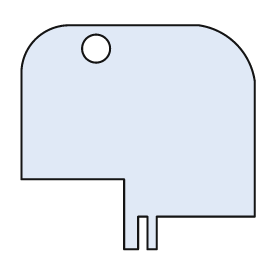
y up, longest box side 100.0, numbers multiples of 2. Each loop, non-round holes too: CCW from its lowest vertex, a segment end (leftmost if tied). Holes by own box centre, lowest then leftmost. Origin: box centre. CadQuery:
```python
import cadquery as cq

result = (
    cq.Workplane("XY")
    .moveTo(-6.0, -48.0)
    .lineTo(0.0, -48.0)
    .lineTo(0.0, -34.0)
    .lineTo(4.0, -34.0)
    .lineTo(4.0, -48.0)
    .lineTo(8.0, -48.0)
    .lineTo(8.0, -34.0)
    .lineTo(50.0, -34.0)
    .lineTo(50.0, 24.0)
    .threePointArc((42.0, 40.0), (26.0, 48.0))
    .lineTo(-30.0, 48.0)
    .threePointArc((-44.0, 42.0), (-50.0, 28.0))
    .lineTo(-50.0, -18.0)
    .lineTo(-6.0, -18.0)
    .close()
    .moveTo(-18.0, 38.0)
    .circle(6.0)
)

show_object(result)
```